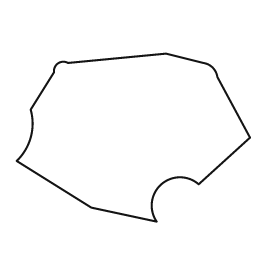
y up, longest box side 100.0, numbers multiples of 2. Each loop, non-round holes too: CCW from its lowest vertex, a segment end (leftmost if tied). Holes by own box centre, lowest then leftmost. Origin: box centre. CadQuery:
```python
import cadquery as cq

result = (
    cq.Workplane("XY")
    .moveTo(10.0, -36.0)
    .threePointArc((12.0, -20.0), (28.0, -20.0))
    .lineTo(50.0, 0.0)
    .lineTo(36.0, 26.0)
    .threePointArc((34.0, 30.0), (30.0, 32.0))
    .lineTo(14.0, 36.0)
    .lineTo(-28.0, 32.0)
    .threePointArc((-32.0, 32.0), (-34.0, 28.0))
    .lineTo(-44.0, 12.0)
    .threePointArc((-44.0, 0.0), (-50.0, -10.0))
    .lineTo(-18.0, -30.0)
    .close()
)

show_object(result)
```